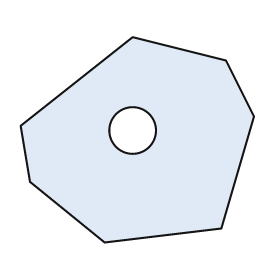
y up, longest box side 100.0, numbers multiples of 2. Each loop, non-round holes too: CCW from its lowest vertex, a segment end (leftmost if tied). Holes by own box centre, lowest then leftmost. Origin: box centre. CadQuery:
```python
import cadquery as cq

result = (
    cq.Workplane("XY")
    .moveTo(-14.0, -44.0)
    .lineTo(36.0, -38.0)
    .lineTo(50.0, 10.0)
    .lineTo(38.0, 34.0)
    .lineTo(-2.0, 44.0)
    .lineTo(-50.0, 6.0)
    .lineTo(-46.0, -18.0)
    .close()
    .moveTo(-2.0, 4.0)
    .circle(10.0)
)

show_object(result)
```